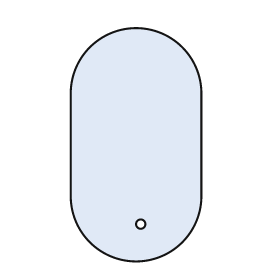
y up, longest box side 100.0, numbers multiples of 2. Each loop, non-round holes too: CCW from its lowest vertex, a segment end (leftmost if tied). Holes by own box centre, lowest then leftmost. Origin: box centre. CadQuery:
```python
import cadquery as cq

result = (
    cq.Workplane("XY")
    .moveTo(-28.0, -22.0)
    .threePointArc((0.0, -50.0), (28.0, -22.0))
    .lineTo(28.0, 22.0)
    .threePointArc((0.0, 50.0), (-28.0, 22.0))
    .close()
    .moveTo(2.0, -34.0)
    .circle(2.0)
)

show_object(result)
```